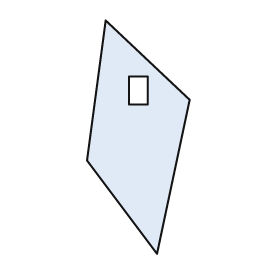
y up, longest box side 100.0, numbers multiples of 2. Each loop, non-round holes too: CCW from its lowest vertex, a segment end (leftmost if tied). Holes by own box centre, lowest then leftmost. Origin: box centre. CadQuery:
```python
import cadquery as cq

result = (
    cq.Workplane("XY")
    .moveTo(8.0, -50.0)
    .lineTo(22.0, 16.0)
    .lineTo(-14.0, 50.0)
    .lineTo(-22.0, -10.0)
    .close()
    .moveTo(-4.0, 14.0)
    .lineTo(4.0, 14.0)
    .lineTo(4.0, 26.0)
    .lineTo(-4.0, 26.0)
    .close()
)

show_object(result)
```